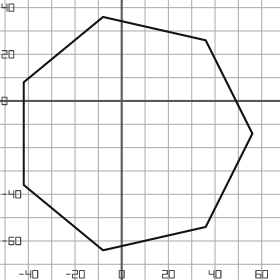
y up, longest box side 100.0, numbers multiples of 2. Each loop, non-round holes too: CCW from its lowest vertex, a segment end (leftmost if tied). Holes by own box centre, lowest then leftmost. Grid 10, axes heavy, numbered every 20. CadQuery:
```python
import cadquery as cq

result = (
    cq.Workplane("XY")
    .moveTo(-8.0, -64.0)
    .lineTo(36.0, -54.0)
    .lineTo(56.0, -14.0)
    .lineTo(36.0, 26.0)
    .lineTo(-8.0, 36.0)
    .lineTo(-42.0, 8.0)
    .lineTo(-42.0, -36.0)
    .close()
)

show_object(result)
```